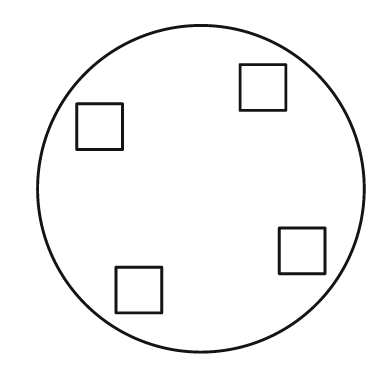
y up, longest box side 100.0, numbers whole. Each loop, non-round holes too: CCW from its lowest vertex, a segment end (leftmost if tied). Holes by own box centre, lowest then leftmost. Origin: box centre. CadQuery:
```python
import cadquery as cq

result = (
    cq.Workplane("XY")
    .moveTo(0.0, 0.0)
    .circle(50.0)
    .moveTo(-26.0, -38.0)
    .lineTo(-12.0, -38.0)
    .lineTo(-12.0, -24.0)
    .lineTo(-26.0, -24.0)
    .close()
    .moveTo(24.0, -26.0)
    .lineTo(38.0, -26.0)
    .lineTo(38.0, -12.0)
    .lineTo(24.0, -12.0)
    .close()
    .moveTo(-38.0, 12.0)
    .lineTo(-24.0, 12.0)
    .lineTo(-24.0, 26.0)
    .lineTo(-38.0, 26.0)
    .close()
    .moveTo(12.0, 24.0)
    .lineTo(26.0, 24.0)
    .lineTo(26.0, 38.0)
    .lineTo(12.0, 38.0)
    .close()
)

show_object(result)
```